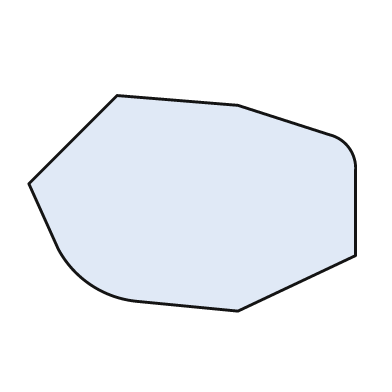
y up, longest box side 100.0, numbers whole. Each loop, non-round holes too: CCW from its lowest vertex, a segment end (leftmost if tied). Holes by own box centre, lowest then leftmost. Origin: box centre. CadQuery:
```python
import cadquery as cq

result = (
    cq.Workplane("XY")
    .moveTo(14.0, -33.0)
    .lineTo(50.0, -16.0)
    .lineTo(50.0, 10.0)
    .threePointArc((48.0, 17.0), (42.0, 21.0))
    .lineTo(14.0, 30.0)
    .lineTo(-23.0, 33.0)
    .lineTo(-50.0, 6.0)
    .lineTo(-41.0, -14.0)
    .threePointArc((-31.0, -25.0), (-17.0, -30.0))
    .close()
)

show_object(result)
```